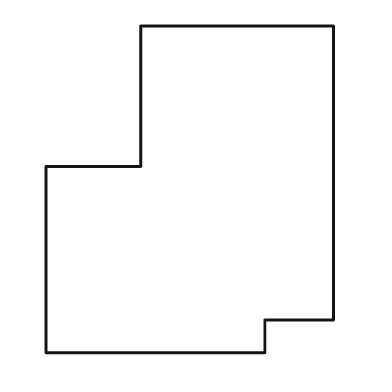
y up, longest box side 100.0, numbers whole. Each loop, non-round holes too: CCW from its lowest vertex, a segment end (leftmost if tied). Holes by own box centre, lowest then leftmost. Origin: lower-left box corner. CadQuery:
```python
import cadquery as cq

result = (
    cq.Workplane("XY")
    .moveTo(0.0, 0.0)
    .lineTo(67.0, 0.0)
    .lineTo(67.0, 10.0)
    .lineTo(88.0, 10.0)
    .lineTo(88.0, 100.0)
    .lineTo(29.0, 100.0)
    .lineTo(29.0, 57.0)
    .lineTo(0.0, 57.0)
    .close()
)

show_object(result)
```